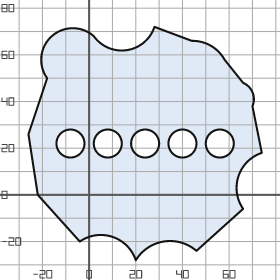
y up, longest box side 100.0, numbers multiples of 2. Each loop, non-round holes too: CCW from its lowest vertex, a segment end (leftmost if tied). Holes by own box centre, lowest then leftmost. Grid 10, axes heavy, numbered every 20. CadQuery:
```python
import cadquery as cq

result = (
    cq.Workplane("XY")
    .moveTo(20.0, -28.0)
    .threePointArc((32.0, -20.0), (46.0, -24.0))
    .lineTo(66.0, -6.0)
    .threePointArc((64.0, 8.0), (74.0, 18.0))
    .lineTo(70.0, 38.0)
    .threePointArc((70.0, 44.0), (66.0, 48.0))
    .lineTo(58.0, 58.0)
    .threePointArc((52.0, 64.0), (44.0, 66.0))
    .lineTo(28.0, 72.0)
    .threePointArc((16.0, 62.0), (2.0, 68.0))
    .threePointArc((-16.0, 68.0), (-18.0, 50.0))
    .lineTo(-26.0, 26.0)
    .lineTo(-22.0, 0.0)
    .lineTo(-4.0, -20.0)
    .threePointArc((10.0, -18.0), (20.0, -28.0))
    .close()
    .moveTo(-8.0, 22.0)
    .circle(6.0)
    .moveTo(8.0, 22.0)
    .circle(6.0)
    .moveTo(24.0, 22.0)
    .circle(6.0)
    .moveTo(40.0, 22.0)
    .circle(6.0)
    .moveTo(56.0, 22.0)
    .circle(6.0)
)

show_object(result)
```